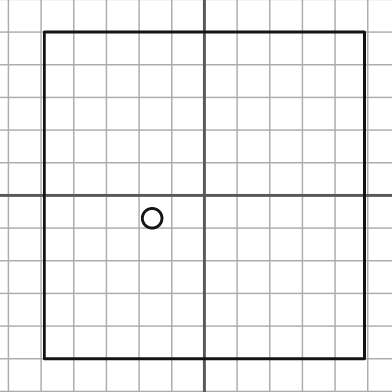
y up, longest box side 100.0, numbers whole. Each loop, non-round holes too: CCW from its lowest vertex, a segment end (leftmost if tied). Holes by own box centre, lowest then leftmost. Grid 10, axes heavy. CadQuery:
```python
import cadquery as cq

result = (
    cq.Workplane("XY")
    .moveTo(-49.0, -50.0)
    .lineTo(49.0, -50.0)
    .lineTo(49.0, 50.0)
    .lineTo(-49.0, 50.0)
    .close()
    .moveTo(-16.0, -7.0)
    .circle(3.0)
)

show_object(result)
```